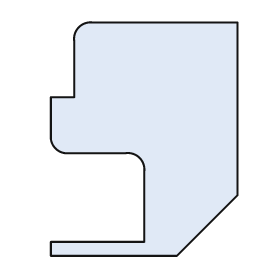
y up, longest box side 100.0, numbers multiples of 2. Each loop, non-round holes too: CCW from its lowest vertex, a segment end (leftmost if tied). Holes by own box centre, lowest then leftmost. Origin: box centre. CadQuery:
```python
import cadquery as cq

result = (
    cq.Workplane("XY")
    .moveTo(-40.0, -50.0)
    .lineTo(14.0, -50.0)
    .lineTo(40.0, -24.0)
    .lineTo(40.0, 50.0)
    .lineTo(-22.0, 50.0)
    .threePointArc((-28.0, 48.0), (-30.0, 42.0))
    .lineTo(-30.0, 18.0)
    .lineTo(-40.0, 18.0)
    .lineTo(-40.0, 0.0)
    .threePointArc((-38.0, -4.0), (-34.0, -6.0))
    .lineTo(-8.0, -6.0)
    .threePointArc((-2.0, -8.0), (0.0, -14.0))
    .lineTo(0.0, -44.0)
    .lineTo(-40.0, -44.0)
    .close()
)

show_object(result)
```